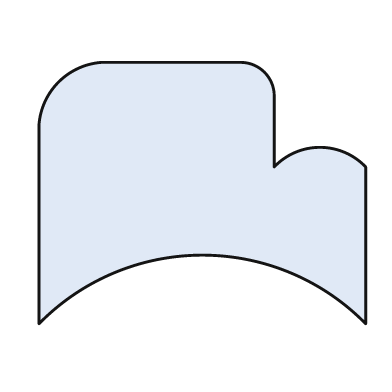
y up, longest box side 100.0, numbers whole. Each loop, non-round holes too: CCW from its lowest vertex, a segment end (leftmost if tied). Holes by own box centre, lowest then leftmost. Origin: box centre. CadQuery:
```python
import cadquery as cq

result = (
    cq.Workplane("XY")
    .moveTo(-50.0, -40.0)
    .threePointArc((0.0, -19.0), (50.0, -40.0))
    .lineTo(50.0, 8.0)
    .threePointArc((36.0, 14.0), (22.0, 8.0))
    .lineTo(22.0, 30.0)
    .threePointArc((19.0, 37.0), (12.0, 40.0))
    .lineTo(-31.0, 40.0)
    .threePointArc((-44.0, 34.0), (-50.0, 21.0))
    .close()
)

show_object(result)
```